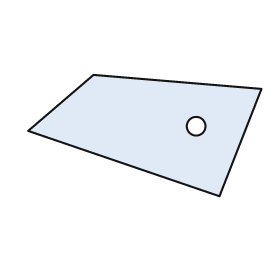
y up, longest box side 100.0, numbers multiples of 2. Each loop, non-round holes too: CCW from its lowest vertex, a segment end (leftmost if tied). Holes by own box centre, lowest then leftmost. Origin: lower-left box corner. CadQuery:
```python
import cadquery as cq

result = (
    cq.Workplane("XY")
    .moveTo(82.0, 0.0)
    .lineTo(100.0, 46.0)
    .lineTo(28.0, 52.0)
    .lineTo(0.0, 28.0)
    .close()
    .moveTo(72.0, 30.0)
    .circle(4.0)
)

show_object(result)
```